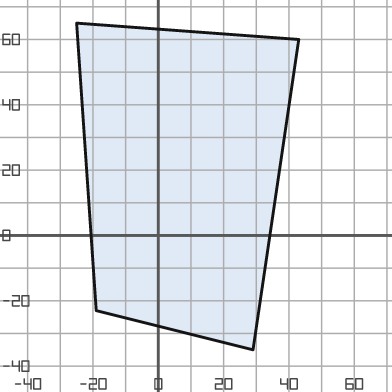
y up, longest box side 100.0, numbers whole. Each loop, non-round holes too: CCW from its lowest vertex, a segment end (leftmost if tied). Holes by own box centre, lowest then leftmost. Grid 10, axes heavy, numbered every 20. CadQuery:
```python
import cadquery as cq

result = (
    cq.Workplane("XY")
    .moveTo(29.0, -35.0)
    .lineTo(43.0, 60.0)
    .lineTo(-25.0, 65.0)
    .lineTo(-19.0, -23.0)
    .close()
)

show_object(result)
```